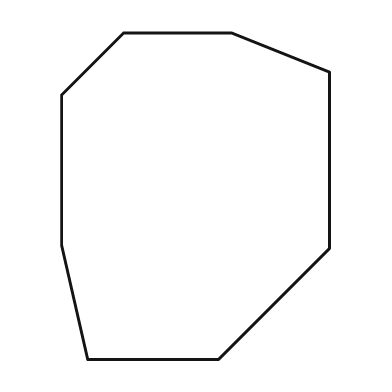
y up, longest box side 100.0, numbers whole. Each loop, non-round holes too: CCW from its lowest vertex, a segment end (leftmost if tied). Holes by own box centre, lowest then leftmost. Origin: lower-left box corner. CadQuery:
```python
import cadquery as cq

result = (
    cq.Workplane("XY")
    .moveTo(8.0, 0.0)
    .lineTo(48.0, 0.0)
    .lineTo(82.0, 34.0)
    .lineTo(82.0, 88.0)
    .lineTo(52.0, 100.0)
    .lineTo(19.0, 100.0)
    .lineTo(0.0, 81.0)
    .lineTo(0.0, 35.0)
    .close()
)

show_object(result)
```